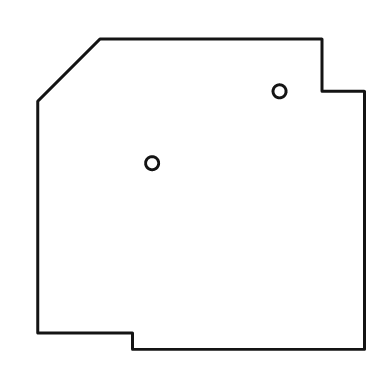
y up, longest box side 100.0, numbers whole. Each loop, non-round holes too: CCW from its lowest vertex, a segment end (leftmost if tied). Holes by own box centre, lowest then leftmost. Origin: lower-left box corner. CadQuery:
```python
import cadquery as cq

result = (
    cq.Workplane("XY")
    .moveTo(29.0, 0.0)
    .lineTo(100.0, 0.0)
    .lineTo(100.0, 79.0)
    .lineTo(87.0, 79.0)
    .lineTo(87.0, 95.0)
    .lineTo(19.0, 95.0)
    .lineTo(0.0, 76.0)
    .lineTo(0.0, 5.0)
    .lineTo(29.0, 5.0)
    .close()
    .moveTo(35.0, 57.0)
    .circle(2.0)
    .moveTo(74.0, 79.0)
    .circle(2.0)
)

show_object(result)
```